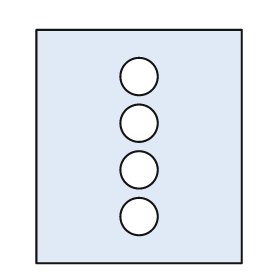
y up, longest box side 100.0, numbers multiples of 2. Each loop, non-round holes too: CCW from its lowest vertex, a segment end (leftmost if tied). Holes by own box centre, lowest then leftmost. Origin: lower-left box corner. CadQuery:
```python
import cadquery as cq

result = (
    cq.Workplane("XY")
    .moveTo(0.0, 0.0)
    .lineTo(88.0, 0.0)
    .lineTo(88.0, 100.0)
    .lineTo(0.0, 100.0)
    .close()
    .moveTo(44.0, 20.0)
    .circle(8.0)
    .moveTo(44.0, 40.0)
    .circle(8.0)
    .moveTo(44.0, 60.0)
    .circle(8.0)
    .moveTo(44.0, 80.0)
    .circle(8.0)
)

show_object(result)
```